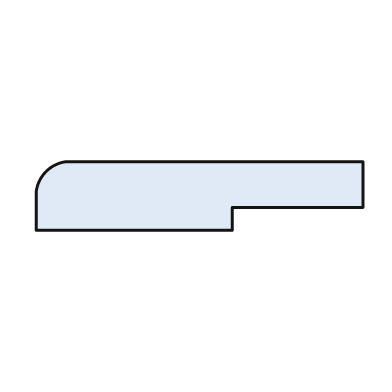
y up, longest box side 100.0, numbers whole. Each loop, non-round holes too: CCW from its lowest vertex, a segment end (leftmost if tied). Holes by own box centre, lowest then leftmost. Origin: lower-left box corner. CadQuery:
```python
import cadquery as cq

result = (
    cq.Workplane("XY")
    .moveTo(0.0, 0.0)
    .lineTo(60.0, 0.0)
    .lineTo(60.0, 7.0)
    .lineTo(100.0, 7.0)
    .lineTo(100.0, 21.0)
    .lineTo(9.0, 21.0)
    .threePointArc((3.0, 18.0), (0.0, 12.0))
    .close()
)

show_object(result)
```